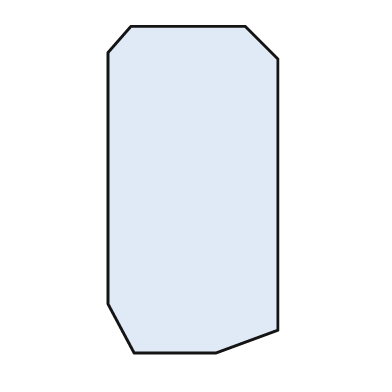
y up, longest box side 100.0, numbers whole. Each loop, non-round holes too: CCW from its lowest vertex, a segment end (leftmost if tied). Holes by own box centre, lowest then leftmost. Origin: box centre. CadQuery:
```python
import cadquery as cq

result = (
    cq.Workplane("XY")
    .moveTo(-18.0, -50.0)
    .lineTo(7.0, -50.0)
    .lineTo(26.0, -43.0)
    .lineTo(26.0, 40.0)
    .lineTo(16.0, 50.0)
    .lineTo(-19.0, 50.0)
    .lineTo(-26.0, 42.0)
    .lineTo(-26.0, -35.0)
    .close()
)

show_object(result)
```